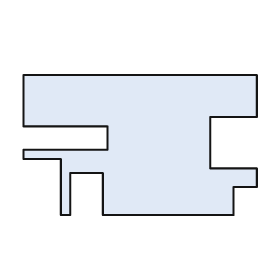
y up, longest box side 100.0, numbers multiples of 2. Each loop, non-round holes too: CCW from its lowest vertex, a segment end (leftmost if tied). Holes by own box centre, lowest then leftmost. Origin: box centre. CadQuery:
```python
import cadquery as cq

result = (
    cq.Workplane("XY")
    .moveTo(-34.0, -30.0)
    .lineTo(-30.0, -30.0)
    .lineTo(-30.0, -12.0)
    .lineTo(-16.0, -12.0)
    .lineTo(-16.0, -30.0)
    .lineTo(40.0, -30.0)
    .lineTo(40.0, -18.0)
    .lineTo(50.0, -18.0)
    .lineTo(50.0, -10.0)
    .lineTo(30.0, -10.0)
    .lineTo(30.0, 12.0)
    .lineTo(50.0, 12.0)
    .lineTo(50.0, 30.0)
    .lineTo(-50.0, 30.0)
    .lineTo(-50.0, 8.0)
    .lineTo(-14.0, 8.0)
    .lineTo(-14.0, -2.0)
    .lineTo(-50.0, -2.0)
    .lineTo(-50.0, -6.0)
    .lineTo(-34.0, -6.0)
    .close()
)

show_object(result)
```